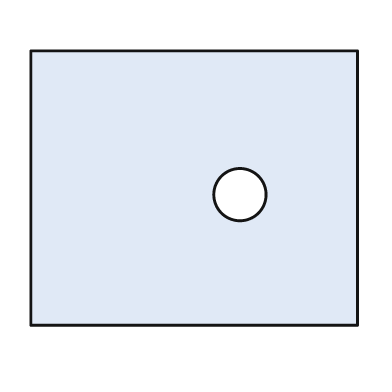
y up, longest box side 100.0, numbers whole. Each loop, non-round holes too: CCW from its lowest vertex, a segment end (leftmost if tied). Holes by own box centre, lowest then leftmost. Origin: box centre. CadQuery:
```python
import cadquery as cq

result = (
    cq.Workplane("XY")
    .moveTo(-50.0, -42.0)
    .lineTo(50.0, -42.0)
    .lineTo(50.0, 42.0)
    .lineTo(-50.0, 42.0)
    .close()
    .moveTo(14.0, -2.0)
    .circle(8.0)
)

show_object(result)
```